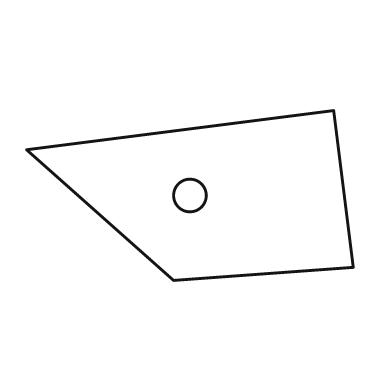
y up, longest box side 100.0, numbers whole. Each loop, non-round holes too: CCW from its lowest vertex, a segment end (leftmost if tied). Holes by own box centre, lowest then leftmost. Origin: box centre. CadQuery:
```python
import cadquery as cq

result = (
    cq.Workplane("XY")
    .moveTo(-5.0, -26.0)
    .lineTo(50.0, -22.0)
    .lineTo(44.0, 26.0)
    .lineTo(-50.0, 14.0)
    .close()
    .moveTo(0.0, 0.0)
    .circle(5.0)
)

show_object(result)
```